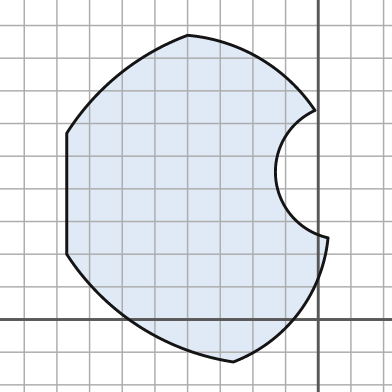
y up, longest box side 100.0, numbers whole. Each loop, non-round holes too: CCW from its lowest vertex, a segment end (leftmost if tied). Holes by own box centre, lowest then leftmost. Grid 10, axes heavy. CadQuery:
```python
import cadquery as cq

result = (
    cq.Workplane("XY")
    .moveTo(-26.0, -13.0)
    .threePointArc((-6.0, 2.0), (3.0, 25.0))
    .threePointArc((-13.0, 43.0), (-1.0, 64.0))
    .threePointArc((-18.0, 80.0), (-40.0, 87.0))
    .threePointArc((-61.0, 75.0), (-77.0, 57.0))
    .lineTo(-77.0, 20.0)
    .threePointArc((-55.0, -2.0), (-26.0, -13.0))
    .close()
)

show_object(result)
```